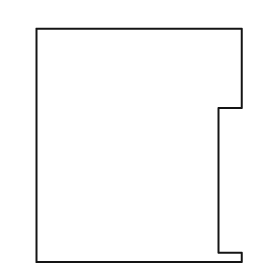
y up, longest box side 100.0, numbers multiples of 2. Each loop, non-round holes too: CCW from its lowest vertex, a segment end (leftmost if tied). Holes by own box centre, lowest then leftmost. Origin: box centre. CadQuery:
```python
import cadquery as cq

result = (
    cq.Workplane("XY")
    .moveTo(-44.0, -50.0)
    .lineTo(44.0, -50.0)
    .lineTo(44.0, -46.0)
    .lineTo(34.0, -46.0)
    .lineTo(34.0, 16.0)
    .lineTo(44.0, 16.0)
    .lineTo(44.0, 50.0)
    .lineTo(-44.0, 50.0)
    .close()
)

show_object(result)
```